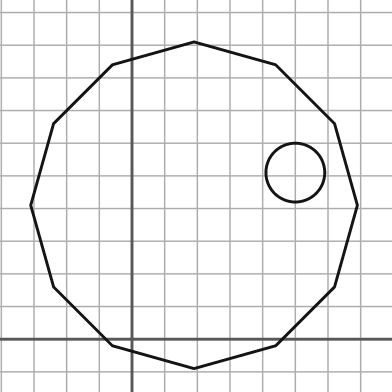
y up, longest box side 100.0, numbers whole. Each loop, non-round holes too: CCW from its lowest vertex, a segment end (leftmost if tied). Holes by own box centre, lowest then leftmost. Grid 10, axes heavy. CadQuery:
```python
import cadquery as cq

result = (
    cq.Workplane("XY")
    .moveTo(19.0, -9.0)
    .lineTo(44.0, -2.0)
    .lineTo(62.0, 16.0)
    .lineTo(69.0, 41.0)
    .lineTo(62.0, 66.0)
    .lineTo(44.0, 84.0)
    .lineTo(19.0, 91.0)
    .lineTo(-6.0, 84.0)
    .lineTo(-24.0, 66.0)
    .lineTo(-31.0, 41.0)
    .lineTo(-24.0, 16.0)
    .lineTo(-6.0, -2.0)
    .close()
    .moveTo(50.0, 51.0)
    .circle(9.0)
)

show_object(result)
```